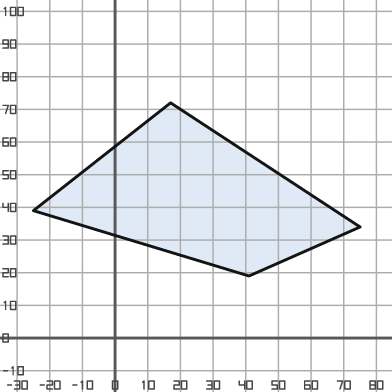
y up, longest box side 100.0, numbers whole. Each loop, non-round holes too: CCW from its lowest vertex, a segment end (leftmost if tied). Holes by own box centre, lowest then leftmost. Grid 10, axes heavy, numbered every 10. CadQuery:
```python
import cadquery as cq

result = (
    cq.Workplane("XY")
    .moveTo(41.0, 19.0)
    .lineTo(75.0, 34.0)
    .lineTo(17.0, 72.0)
    .lineTo(-25.0, 39.0)
    .close()
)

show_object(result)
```